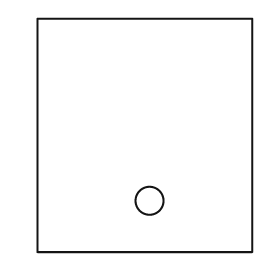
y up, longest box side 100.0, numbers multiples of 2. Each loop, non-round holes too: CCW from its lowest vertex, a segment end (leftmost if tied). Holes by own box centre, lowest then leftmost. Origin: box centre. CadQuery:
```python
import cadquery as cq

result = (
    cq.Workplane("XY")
    .moveTo(-46.0, -50.0)
    .lineTo(46.0, -50.0)
    .lineTo(46.0, 50.0)
    .lineTo(-46.0, 50.0)
    .close()
    .moveTo(2.0, -28.0)
    .circle(6.0)
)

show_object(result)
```